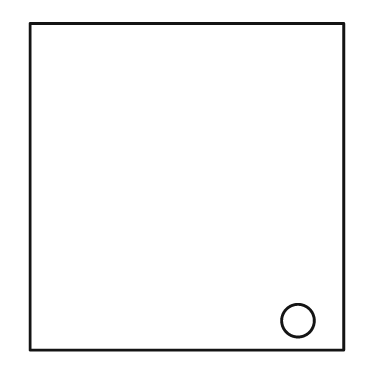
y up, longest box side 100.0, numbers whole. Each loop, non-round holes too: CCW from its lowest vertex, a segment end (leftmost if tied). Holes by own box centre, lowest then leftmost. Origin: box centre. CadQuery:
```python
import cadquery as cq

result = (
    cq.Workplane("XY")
    .moveTo(-48.0, -50.0)
    .lineTo(48.0, -50.0)
    .lineTo(48.0, 50.0)
    .lineTo(-48.0, 50.0)
    .close()
    .moveTo(34.0, -41.0)
    .circle(5.0)
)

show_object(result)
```